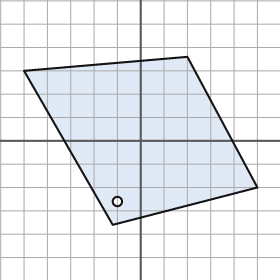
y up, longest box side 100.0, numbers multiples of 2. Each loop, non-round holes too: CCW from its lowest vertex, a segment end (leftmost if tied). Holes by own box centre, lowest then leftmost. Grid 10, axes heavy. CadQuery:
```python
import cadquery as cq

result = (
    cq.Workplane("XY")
    .moveTo(-12.0, -36.0)
    .lineTo(50.0, -20.0)
    .lineTo(20.0, 36.0)
    .lineTo(-50.0, 30.0)
    .close()
    .moveTo(-10.0, -26.0)
    .circle(2.0)
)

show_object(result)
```